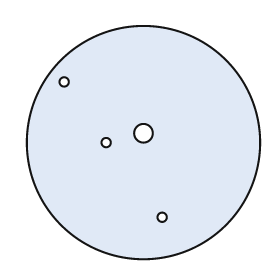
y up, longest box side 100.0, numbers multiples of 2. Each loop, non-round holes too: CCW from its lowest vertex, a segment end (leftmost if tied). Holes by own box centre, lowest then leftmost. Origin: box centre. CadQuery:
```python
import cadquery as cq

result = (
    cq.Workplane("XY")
    .moveTo(0.0, 0.0)
    .circle(50.0)
    .moveTo(8.0, -32.0)
    .circle(2.0)
    .moveTo(-16.0, 0.0)
    .circle(2.0)
    .moveTo(0.0, 4.0)
    .circle(4.0)
    .moveTo(-34.0, 26.0)
    .circle(2.0)
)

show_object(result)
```